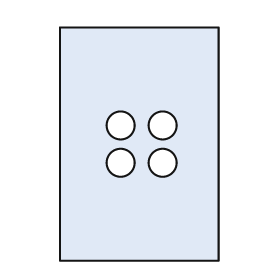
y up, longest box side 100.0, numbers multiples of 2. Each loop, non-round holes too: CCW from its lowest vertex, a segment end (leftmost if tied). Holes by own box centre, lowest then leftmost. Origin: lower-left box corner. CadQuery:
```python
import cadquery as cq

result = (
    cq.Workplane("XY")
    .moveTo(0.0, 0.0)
    .lineTo(68.0, 0.0)
    .lineTo(68.0, 100.0)
    .lineTo(0.0, 100.0)
    .close()
    .moveTo(26.0, 42.0)
    .circle(6.0)
    .moveTo(44.0, 42.0)
    .circle(6.0)
    .moveTo(26.0, 58.0)
    .circle(6.0)
    .moveTo(44.0, 58.0)
    .circle(6.0)
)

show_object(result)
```